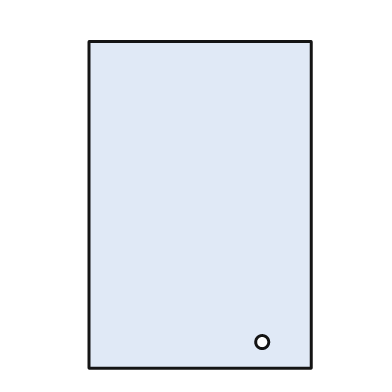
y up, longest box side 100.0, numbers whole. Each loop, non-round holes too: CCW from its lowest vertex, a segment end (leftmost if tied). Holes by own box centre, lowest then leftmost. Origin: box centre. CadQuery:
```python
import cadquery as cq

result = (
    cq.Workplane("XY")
    .moveTo(-34.0, -50.0)
    .lineTo(34.0, -50.0)
    .lineTo(34.0, 50.0)
    .lineTo(-34.0, 50.0)
    .close()
    .moveTo(19.0, -42.0)
    .circle(2.0)
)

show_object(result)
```